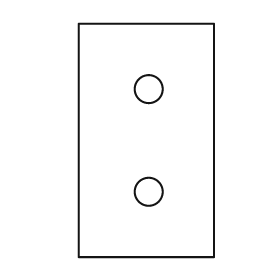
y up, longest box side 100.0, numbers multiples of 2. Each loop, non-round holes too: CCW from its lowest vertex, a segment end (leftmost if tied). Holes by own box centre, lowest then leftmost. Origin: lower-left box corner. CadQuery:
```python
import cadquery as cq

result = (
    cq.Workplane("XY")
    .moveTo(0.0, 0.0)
    .lineTo(58.0, 0.0)
    .lineTo(58.0, 100.0)
    .lineTo(0.0, 100.0)
    .close()
    .moveTo(30.0, 28.0)
    .circle(6.0)
    .moveTo(30.0, 72.0)
    .circle(6.0)
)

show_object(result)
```